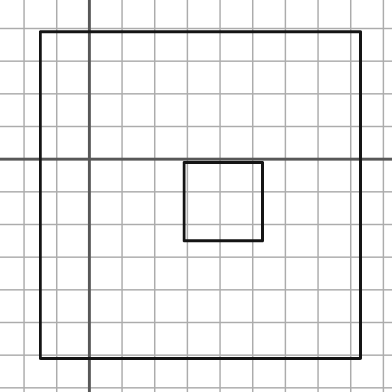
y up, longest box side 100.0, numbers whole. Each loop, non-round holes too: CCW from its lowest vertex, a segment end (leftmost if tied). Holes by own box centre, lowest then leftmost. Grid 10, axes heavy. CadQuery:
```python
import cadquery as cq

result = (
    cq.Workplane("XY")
    .moveTo(-15.0, -61.0)
    .lineTo(83.0, -61.0)
    .lineTo(83.0, 39.0)
    .lineTo(-15.0, 39.0)
    .close()
    .moveTo(29.0, -25.0)
    .lineTo(53.0, -25.0)
    .lineTo(53.0, -1.0)
    .lineTo(29.0, -1.0)
    .close()
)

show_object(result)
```